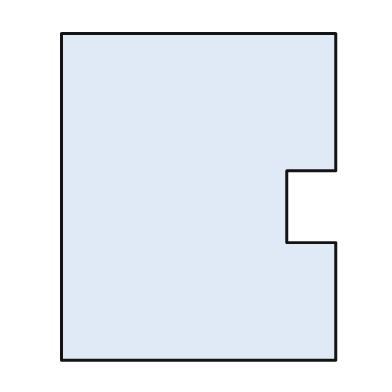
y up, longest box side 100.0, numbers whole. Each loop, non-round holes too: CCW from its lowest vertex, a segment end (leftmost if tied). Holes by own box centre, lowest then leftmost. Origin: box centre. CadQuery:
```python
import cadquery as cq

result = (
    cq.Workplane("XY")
    .moveTo(-42.0, -50.0)
    .lineTo(42.0, -50.0)
    .lineTo(42.0, -14.0)
    .lineTo(27.0, -14.0)
    .lineTo(27.0, 8.0)
    .lineTo(42.0, 8.0)
    .lineTo(42.0, 50.0)
    .lineTo(-42.0, 50.0)
    .close()
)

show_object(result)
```